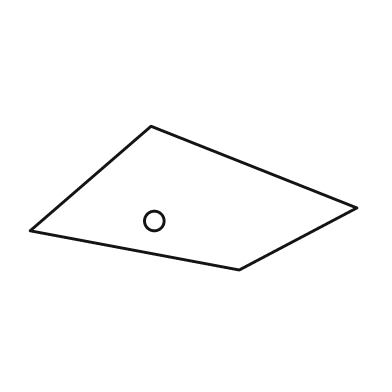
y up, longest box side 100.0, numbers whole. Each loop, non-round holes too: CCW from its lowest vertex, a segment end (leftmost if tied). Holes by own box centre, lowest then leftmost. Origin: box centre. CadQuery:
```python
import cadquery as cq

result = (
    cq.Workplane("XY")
    .moveTo(14.0, -22.0)
    .lineTo(50.0, -3.0)
    .lineTo(-13.0, 22.0)
    .lineTo(-50.0, -10.0)
    .close()
    .moveTo(-12.0, -7.0)
    .circle(3.0)
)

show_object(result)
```